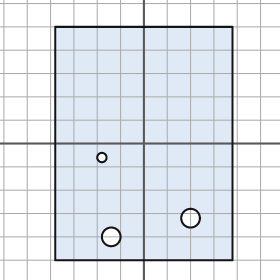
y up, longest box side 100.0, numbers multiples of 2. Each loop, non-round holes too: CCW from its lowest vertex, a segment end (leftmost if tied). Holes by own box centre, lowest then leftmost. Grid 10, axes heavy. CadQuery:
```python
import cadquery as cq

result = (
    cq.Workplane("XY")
    .moveTo(-38.0, -50.0)
    .lineTo(38.0, -50.0)
    .lineTo(38.0, 50.0)
    .lineTo(-38.0, 50.0)
    .close()
    .moveTo(-14.0, -40.0)
    .circle(4.0)
    .moveTo(20.0, -32.0)
    .circle(4.0)
    .moveTo(-18.0, -6.0)
    .circle(2.0)
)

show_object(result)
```